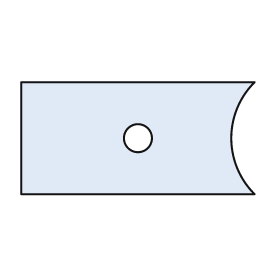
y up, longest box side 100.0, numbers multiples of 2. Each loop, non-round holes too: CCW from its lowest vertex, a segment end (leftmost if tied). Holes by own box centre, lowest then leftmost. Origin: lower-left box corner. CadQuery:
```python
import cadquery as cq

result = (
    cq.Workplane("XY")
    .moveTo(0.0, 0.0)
    .lineTo(100.0, 0.0)
    .threePointArc((90.0, 24.0), (100.0, 48.0))
    .lineTo(0.0, 48.0)
    .close()
    .moveTo(50.0, 24.0)
    .circle(6.0)
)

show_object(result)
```